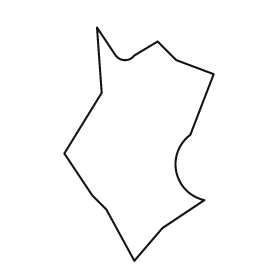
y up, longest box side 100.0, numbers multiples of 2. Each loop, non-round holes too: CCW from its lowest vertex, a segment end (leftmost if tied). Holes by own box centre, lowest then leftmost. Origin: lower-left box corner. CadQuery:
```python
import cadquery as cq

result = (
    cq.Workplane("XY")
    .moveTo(30.0, 0.0)
    .lineTo(42.0, 14.0)
    .lineTo(60.0, 26.0)
    .threePointArc((48.0, 38.0), (54.0, 54.0))
    .lineTo(64.0, 80.0)
    .lineTo(48.0, 86.0)
    .lineTo(40.0, 94.0)
    .lineTo(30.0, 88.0)
    .threePointArc((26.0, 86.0), (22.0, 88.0))
    .lineTo(14.0, 100.0)
    .lineTo(16.0, 72.0)
    .lineTo(0.0, 46.0)
    .lineTo(12.0, 28.0)
    .lineTo(18.0, 22.0)
    .close()
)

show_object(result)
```